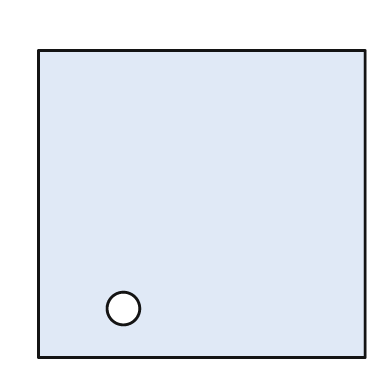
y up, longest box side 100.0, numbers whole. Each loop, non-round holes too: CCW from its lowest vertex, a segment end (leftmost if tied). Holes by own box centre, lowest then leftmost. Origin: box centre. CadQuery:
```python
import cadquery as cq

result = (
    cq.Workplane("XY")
    .moveTo(-50.0, -47.0)
    .lineTo(50.0, -47.0)
    .lineTo(50.0, 47.0)
    .lineTo(-50.0, 47.0)
    .close()
    .moveTo(-24.0, -32.0)
    .circle(5.0)
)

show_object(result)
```